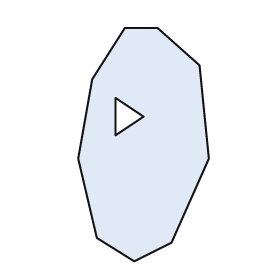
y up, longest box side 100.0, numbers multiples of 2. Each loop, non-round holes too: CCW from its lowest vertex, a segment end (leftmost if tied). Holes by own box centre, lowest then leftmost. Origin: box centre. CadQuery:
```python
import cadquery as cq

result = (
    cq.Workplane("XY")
    .moveTo(-4.0, -50.0)
    .lineTo(12.0, -42.0)
    .lineTo(28.0, -6.0)
    .lineTo(24.0, 34.0)
    .lineTo(6.0, 50.0)
    .lineTo(-8.0, 50.0)
    .lineTo(-22.0, 28.0)
    .lineTo(-28.0, -6.0)
    .lineTo(-20.0, -40.0)
    .close()
    .moveTo(-12.0, 4.0)
    .lineTo(0.0, 12.0)
    .lineTo(-12.0, 20.0)
    .close()
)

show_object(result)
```